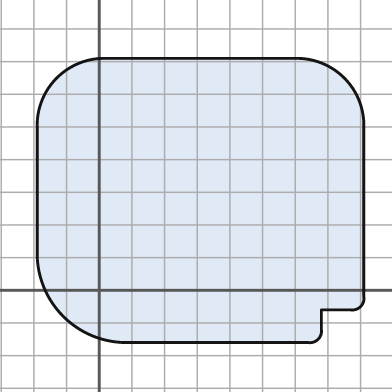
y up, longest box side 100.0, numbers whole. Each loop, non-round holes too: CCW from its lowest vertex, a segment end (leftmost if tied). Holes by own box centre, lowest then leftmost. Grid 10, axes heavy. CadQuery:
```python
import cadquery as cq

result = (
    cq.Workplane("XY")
    .moveTo(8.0, -16.0)
    .lineTo(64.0, -16.0)
    .threePointArc((67.0, -15.0), (68.0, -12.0))
    .lineTo(68.0, -6.0)
    .lineTo(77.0, -6.0)
    .threePointArc((80.0, -5.0), (81.0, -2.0))
    .lineTo(81.0, 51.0)
    .threePointArc((75.0, 65.0), (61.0, 71.0))
    .lineTo(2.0, 71.0)
    .threePointArc((-13.0, 65.0), (-19.0, 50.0))
    .lineTo(-19.0, 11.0)
    .threePointArc((-11.0, -8.0), (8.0, -16.0))
    .close()
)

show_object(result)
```